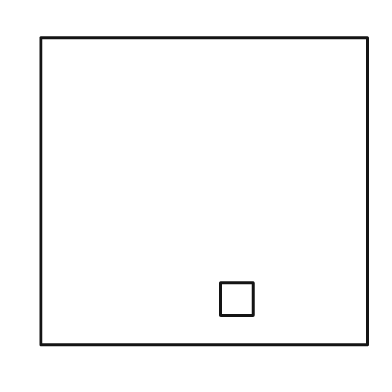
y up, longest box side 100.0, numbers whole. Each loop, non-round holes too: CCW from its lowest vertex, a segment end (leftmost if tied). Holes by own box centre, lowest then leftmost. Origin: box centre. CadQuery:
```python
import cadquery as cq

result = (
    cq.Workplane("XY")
    .moveTo(-50.0, -47.0)
    .lineTo(50.0, -47.0)
    .lineTo(50.0, 47.0)
    .lineTo(-50.0, 47.0)
    .close()
    .moveTo(5.0, -38.0)
    .lineTo(15.0, -38.0)
    .lineTo(15.0, -28.0)
    .lineTo(5.0, -28.0)
    .close()
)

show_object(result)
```